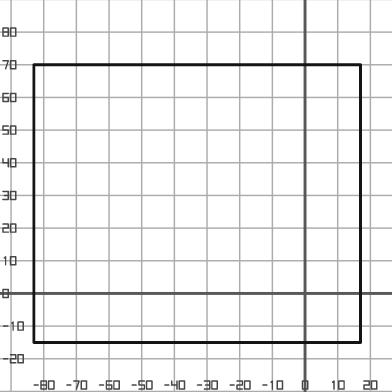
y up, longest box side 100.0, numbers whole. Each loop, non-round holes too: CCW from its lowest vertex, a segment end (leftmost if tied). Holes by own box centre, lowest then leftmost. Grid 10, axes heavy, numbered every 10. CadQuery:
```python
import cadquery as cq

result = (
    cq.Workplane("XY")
    .moveTo(-83.0, -15.0)
    .lineTo(17.0, -15.0)
    .lineTo(17.0, 70.0)
    .lineTo(-83.0, 70.0)
    .close()
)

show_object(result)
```